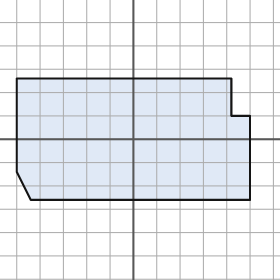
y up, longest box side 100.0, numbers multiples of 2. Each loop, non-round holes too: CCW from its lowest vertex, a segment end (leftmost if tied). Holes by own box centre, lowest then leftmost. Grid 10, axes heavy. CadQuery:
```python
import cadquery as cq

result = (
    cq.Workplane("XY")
    .moveTo(-44.0, -26.0)
    .lineTo(50.0, -26.0)
    .lineTo(50.0, 10.0)
    .lineTo(42.0, 10.0)
    .lineTo(42.0, 26.0)
    .lineTo(-50.0, 26.0)
    .lineTo(-50.0, -14.0)
    .close()
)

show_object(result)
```